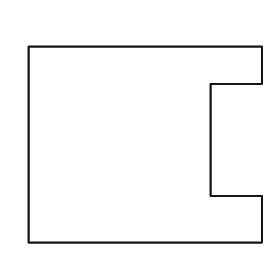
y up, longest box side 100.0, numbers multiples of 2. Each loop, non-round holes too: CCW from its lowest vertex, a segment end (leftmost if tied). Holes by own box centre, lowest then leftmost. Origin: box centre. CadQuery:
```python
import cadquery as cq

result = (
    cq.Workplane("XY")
    .moveTo(-50.0, -42.0)
    .lineTo(50.0, -42.0)
    .lineTo(50.0, -22.0)
    .lineTo(28.0, -22.0)
    .lineTo(28.0, 26.0)
    .lineTo(50.0, 26.0)
    .lineTo(50.0, 42.0)
    .lineTo(-50.0, 42.0)
    .close()
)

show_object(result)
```